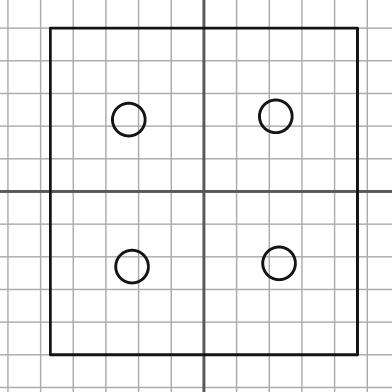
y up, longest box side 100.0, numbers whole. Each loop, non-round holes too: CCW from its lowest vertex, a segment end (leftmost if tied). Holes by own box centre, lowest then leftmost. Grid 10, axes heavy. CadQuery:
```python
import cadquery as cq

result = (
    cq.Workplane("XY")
    .moveTo(-47.0, -50.0)
    .lineTo(47.0, -50.0)
    .lineTo(47.0, 50.0)
    .lineTo(-47.0, 50.0)
    .close()
    .moveTo(-22.0, -23.0)
    .circle(5.0)
    .moveTo(23.0, -22.0)
    .circle(5.0)
    .moveTo(-23.0, 22.0)
    .circle(5.0)
    .moveTo(22.0, 23.0)
    .circle(5.0)
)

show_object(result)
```